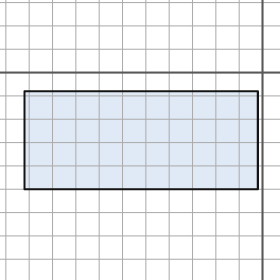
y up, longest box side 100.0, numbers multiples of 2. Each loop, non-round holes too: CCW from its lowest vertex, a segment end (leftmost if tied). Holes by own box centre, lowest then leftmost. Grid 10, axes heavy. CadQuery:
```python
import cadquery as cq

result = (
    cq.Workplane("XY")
    .moveTo(-102.0, -50.0)
    .lineTo(-2.0, -50.0)
    .lineTo(-2.0, -8.0)
    .lineTo(-102.0, -8.0)
    .close()
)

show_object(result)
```